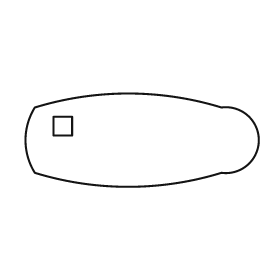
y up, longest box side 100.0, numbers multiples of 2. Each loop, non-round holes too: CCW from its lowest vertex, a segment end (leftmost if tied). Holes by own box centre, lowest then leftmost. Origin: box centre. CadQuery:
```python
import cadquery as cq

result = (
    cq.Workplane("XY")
    .moveTo(-46.0, -14.0)
    .threePointArc((-6.0, -20.0), (34.0, -14.0))
    .threePointArc((50.0, 0.0), (34.0, 14.0))
    .threePointArc((-6.0, 20.0), (-46.0, 14.0))
    .threePointArc((-50.0, 0.0), (-46.0, -14.0))
    .close()
    .moveTo(-38.0, 2.0)
    .lineTo(-30.0, 2.0)
    .lineTo(-30.0, 10.0)
    .lineTo(-38.0, 10.0)
    .close()
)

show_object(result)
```